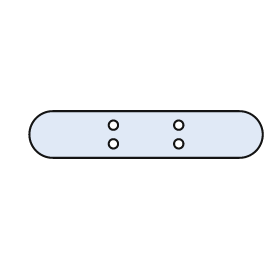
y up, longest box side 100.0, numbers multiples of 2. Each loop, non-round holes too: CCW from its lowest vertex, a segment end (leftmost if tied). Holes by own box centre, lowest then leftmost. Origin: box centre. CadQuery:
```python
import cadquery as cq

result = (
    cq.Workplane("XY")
    .moveTo(-40.0, -10.0)
    .lineTo(40.0, -10.0)
    .threePointArc((50.0, 0.0), (40.0, 10.0))
    .lineTo(-40.0, 10.0)
    .threePointArc((-50.0, 0.0), (-40.0, -10.0))
    .close()
    .moveTo(-14.0, -4.0)
    .circle(2.0)
    .moveTo(14.0, -4.0)
    .circle(2.0)
    .moveTo(-14.0, 4.0)
    .circle(2.0)
    .moveTo(14.0, 4.0)
    .circle(2.0)
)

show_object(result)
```